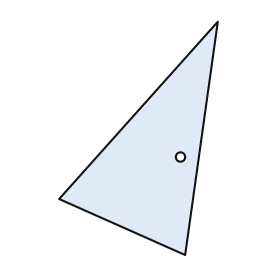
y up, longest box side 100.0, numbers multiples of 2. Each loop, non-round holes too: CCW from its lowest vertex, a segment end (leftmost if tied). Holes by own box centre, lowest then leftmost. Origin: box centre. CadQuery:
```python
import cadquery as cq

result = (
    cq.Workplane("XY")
    .moveTo(20.0, -50.0)
    .lineTo(34.0, 50.0)
    .lineTo(-34.0, -26.0)
    .close()
    .moveTo(18.0, -8.0)
    .circle(2.0)
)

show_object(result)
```